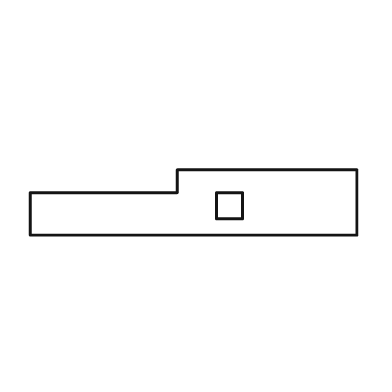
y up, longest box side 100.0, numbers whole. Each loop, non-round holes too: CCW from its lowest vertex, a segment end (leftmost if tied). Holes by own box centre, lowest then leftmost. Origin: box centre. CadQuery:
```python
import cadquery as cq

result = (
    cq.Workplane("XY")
    .moveTo(-50.0, -10.0)
    .lineTo(50.0, -10.0)
    .lineTo(50.0, 10.0)
    .lineTo(-5.0, 10.0)
    .lineTo(-5.0, 3.0)
    .lineTo(-50.0, 3.0)
    .close()
    .moveTo(7.0, -5.0)
    .lineTo(15.0, -5.0)
    .lineTo(15.0, 3.0)
    .lineTo(7.0, 3.0)
    .close()
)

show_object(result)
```